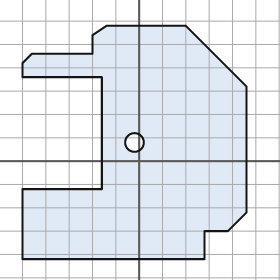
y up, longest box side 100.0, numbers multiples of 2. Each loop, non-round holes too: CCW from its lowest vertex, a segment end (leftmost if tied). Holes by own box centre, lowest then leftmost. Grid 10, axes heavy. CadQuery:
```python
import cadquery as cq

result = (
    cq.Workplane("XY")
    .moveTo(-50.0, -42.0)
    .lineTo(28.0, -42.0)
    .lineTo(28.0, -30.0)
    .lineTo(38.0, -30.0)
    .lineTo(46.0, -22.0)
    .lineTo(46.0, 32.0)
    .lineTo(20.0, 58.0)
    .lineTo(-14.0, 58.0)
    .lineTo(-20.0, 54.0)
    .lineTo(-20.0, 46.0)
    .lineTo(-46.0, 46.0)
    .lineTo(-50.0, 42.0)
    .lineTo(-50.0, 36.0)
    .lineTo(-16.0, 36.0)
    .lineTo(-16.0, -12.0)
    .lineTo(-50.0, -12.0)
    .close()
    .moveTo(-2.0, 8.0)
    .circle(4.0)
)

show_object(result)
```